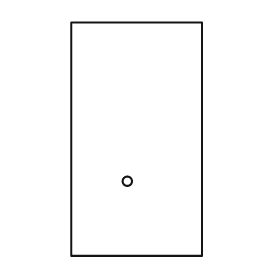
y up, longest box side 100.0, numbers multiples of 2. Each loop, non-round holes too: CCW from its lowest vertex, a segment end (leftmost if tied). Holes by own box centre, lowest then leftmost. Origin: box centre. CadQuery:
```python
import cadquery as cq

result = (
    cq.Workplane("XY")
    .moveTo(-28.0, -50.0)
    .lineTo(28.0, -50.0)
    .lineTo(28.0, 50.0)
    .lineTo(-28.0, 50.0)
    .close()
    .moveTo(-4.0, -18.0)
    .circle(2.0)
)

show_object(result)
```